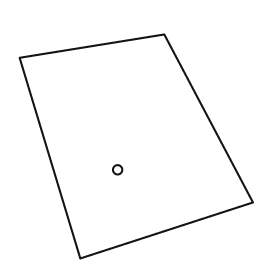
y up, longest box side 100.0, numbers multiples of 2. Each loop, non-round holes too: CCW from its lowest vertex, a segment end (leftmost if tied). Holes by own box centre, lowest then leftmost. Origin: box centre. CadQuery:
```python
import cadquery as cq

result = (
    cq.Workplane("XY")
    .moveTo(-24.0, -48.0)
    .lineTo(50.0, -24.0)
    .lineTo(12.0, 48.0)
    .lineTo(-50.0, 38.0)
    .close()
    .moveTo(-8.0, -10.0)
    .circle(2.0)
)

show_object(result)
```